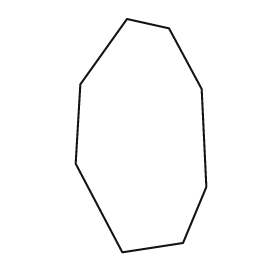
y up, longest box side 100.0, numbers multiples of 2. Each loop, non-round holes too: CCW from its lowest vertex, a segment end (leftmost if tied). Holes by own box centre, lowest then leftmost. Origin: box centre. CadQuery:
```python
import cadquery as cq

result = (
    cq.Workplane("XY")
    .moveTo(-8.0, -50.0)
    .lineTo(18.0, -46.0)
    .lineTo(28.0, -22.0)
    .lineTo(26.0, 20.0)
    .lineTo(12.0, 46.0)
    .lineTo(-6.0, 50.0)
    .lineTo(-26.0, 22.0)
    .lineTo(-28.0, -12.0)
    .close()
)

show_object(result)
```